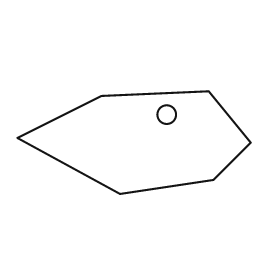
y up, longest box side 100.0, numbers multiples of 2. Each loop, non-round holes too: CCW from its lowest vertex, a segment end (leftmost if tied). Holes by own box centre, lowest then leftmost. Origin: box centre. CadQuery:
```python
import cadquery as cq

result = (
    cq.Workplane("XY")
    .moveTo(-6.0, -22.0)
    .lineTo(34.0, -16.0)
    .lineTo(50.0, 0.0)
    .lineTo(32.0, 22.0)
    .lineTo(-14.0, 20.0)
    .lineTo(-50.0, 2.0)
    .close()
    .moveTo(14.0, 12.0)
    .circle(4.0)
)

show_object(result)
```